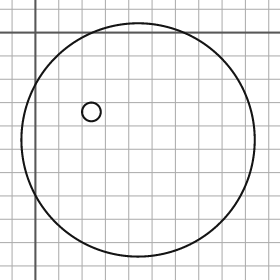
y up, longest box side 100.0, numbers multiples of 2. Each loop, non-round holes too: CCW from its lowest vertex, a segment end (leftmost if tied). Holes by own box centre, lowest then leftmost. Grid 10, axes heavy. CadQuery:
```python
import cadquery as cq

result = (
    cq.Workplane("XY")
    .moveTo(44.0, -46.0)
    .circle(50.0)
    .moveTo(24.0, -34.0)
    .circle(4.0)
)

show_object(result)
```